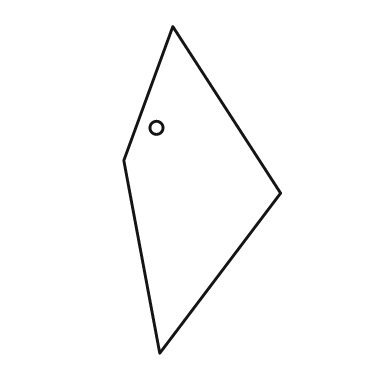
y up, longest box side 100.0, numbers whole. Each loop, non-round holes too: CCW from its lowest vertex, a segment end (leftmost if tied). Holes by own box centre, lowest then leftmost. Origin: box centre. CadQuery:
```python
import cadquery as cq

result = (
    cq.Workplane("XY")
    .moveTo(-13.0, -50.0)
    .lineTo(24.0, -1.0)
    .lineTo(-9.0, 50.0)
    .lineTo(-24.0, 9.0)
    .close()
    .moveTo(-14.0, 19.0)
    .circle(2.0)
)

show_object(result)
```